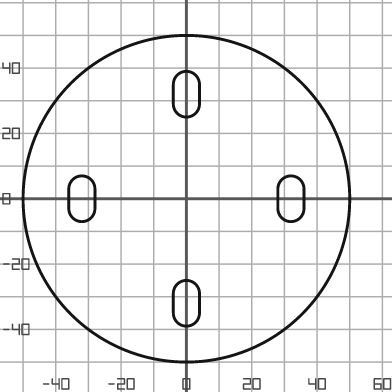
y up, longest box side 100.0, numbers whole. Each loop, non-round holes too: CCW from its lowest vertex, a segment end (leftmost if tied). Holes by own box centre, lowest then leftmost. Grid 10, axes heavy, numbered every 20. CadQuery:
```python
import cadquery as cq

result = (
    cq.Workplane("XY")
    .moveTo(0.0, 0.0)
    .circle(50.0)
    .moveTo(-4.0, -35.0)
    .threePointArc((0.0, -39.0), (4.0, -35.0))
    .lineTo(4.0, -29.0)
    .threePointArc((0.0, -25.0), (-4.0, -29.0))
    .close()
    .moveTo(-36.0, -3.0)
    .threePointArc((-32.0, -7.0), (-28.0, -3.0))
    .lineTo(-28.0, 3.0)
    .threePointArc((-32.0, 7.0), (-36.0, 3.0))
    .close()
    .moveTo(28.0, -3.0)
    .threePointArc((32.0, -7.0), (36.0, -3.0))
    .lineTo(36.0, 3.0)
    .threePointArc((32.0, 7.0), (28.0, 3.0))
    .close()
    .moveTo(-4.0, 29.0)
    .threePointArc((0.0, 25.0), (4.0, 29.0))
    .lineTo(4.0, 35.0)
    .threePointArc((0.0, 39.0), (-4.0, 35.0))
    .close()
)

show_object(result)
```